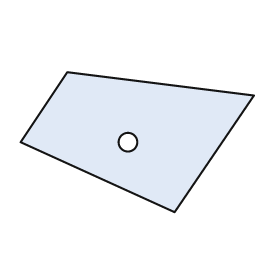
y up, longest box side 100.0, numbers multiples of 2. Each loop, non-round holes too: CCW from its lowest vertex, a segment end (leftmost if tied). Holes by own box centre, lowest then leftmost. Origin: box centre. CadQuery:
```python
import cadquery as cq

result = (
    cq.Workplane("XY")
    .moveTo(16.0, -30.0)
    .lineTo(50.0, 20.0)
    .lineTo(-30.0, 30.0)
    .lineTo(-50.0, 0.0)
    .close()
    .moveTo(-4.0, 0.0)
    .circle(4.0)
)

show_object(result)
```